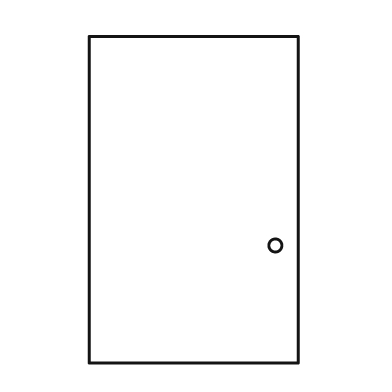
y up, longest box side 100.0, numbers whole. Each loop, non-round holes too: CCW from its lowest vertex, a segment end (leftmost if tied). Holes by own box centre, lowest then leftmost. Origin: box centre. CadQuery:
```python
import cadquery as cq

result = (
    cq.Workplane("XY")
    .moveTo(-32.0, -50.0)
    .lineTo(32.0, -50.0)
    .lineTo(32.0, 50.0)
    .lineTo(-32.0, 50.0)
    .close()
    .moveTo(25.0, -14.0)
    .circle(2.0)
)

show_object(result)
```